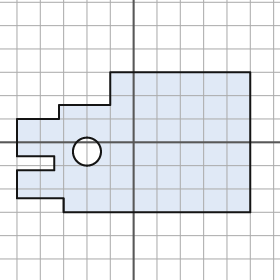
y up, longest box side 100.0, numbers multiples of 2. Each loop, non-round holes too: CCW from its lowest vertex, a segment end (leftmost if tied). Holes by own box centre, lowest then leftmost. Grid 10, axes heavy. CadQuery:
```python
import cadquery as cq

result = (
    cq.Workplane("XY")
    .moveTo(-30.0, -30.0)
    .lineTo(50.0, -30.0)
    .lineTo(50.0, 30.0)
    .lineTo(-10.0, 30.0)
    .lineTo(-10.0, 16.0)
    .lineTo(-32.0, 16.0)
    .lineTo(-32.0, 10.0)
    .lineTo(-50.0, 10.0)
    .lineTo(-50.0, -6.0)
    .lineTo(-34.0, -6.0)
    .lineTo(-34.0, -12.0)
    .lineTo(-50.0, -12.0)
    .lineTo(-50.0, -24.0)
    .lineTo(-30.0, -24.0)
    .close()
    .moveTo(-20.0, -4.0)
    .circle(6.0)
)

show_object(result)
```